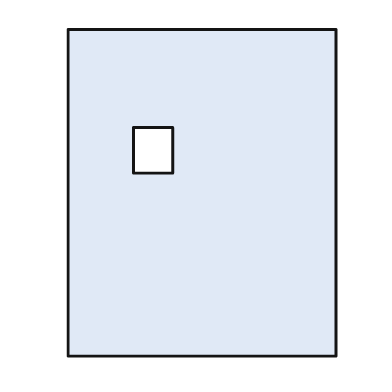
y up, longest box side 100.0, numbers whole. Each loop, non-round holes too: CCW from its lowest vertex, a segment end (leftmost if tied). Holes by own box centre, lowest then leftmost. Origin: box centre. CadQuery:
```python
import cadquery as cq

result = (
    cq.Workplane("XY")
    .moveTo(-41.0, -50.0)
    .lineTo(41.0, -50.0)
    .lineTo(41.0, 50.0)
    .lineTo(-41.0, 50.0)
    .close()
    .moveTo(-21.0, 6.0)
    .lineTo(-9.0, 6.0)
    .lineTo(-9.0, 20.0)
    .lineTo(-21.0, 20.0)
    .close()
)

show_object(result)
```